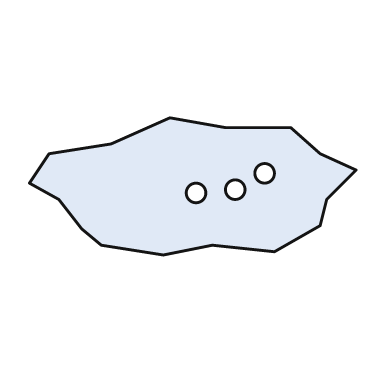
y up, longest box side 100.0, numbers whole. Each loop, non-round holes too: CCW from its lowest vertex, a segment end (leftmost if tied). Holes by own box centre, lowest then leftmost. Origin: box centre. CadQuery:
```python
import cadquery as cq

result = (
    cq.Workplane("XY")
    .moveTo(-9.0, -21.0)
    .lineTo(6.0, -18.0)
    .lineTo(25.0, -20.0)
    .lineTo(39.0, -12.0)
    .lineTo(41.0, -4.0)
    .lineTo(50.0, 5.0)
    .lineTo(39.0, 10.0)
    .lineTo(30.0, 18.0)
    .lineTo(10.0, 18.0)
    .lineTo(-7.0, 21.0)
    .lineTo(-25.0, 13.0)
    .lineTo(-44.0, 10.0)
    .lineTo(-50.0, 1.0)
    .lineTo(-41.0, -4.0)
    .lineTo(-34.0, -13.0)
    .lineTo(-28.0, -18.0)
    .close()
    .moveTo(1.0, -2.0)
    .circle(3.0)
    .moveTo(13.0, -1.0)
    .circle(3.0)
    .moveTo(22.0, 4.0)
    .circle(3.0)
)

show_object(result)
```